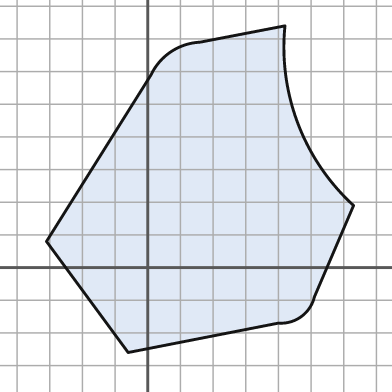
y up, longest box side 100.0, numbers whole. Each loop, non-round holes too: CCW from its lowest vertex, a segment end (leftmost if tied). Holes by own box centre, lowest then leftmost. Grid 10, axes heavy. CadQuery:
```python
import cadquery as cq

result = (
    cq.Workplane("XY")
    .moveTo(-6.0, -26.0)
    .lineTo(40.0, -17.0)
    .threePointArc((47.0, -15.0), (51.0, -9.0))
    .lineTo(63.0, 19.0)
    .threePointArc((46.0, 44.0), (42.0, 74.0))
    .lineTo(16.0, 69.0)
    .threePointArc((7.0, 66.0), (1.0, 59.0))
    .lineTo(-31.0, 8.0)
    .close()
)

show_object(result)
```